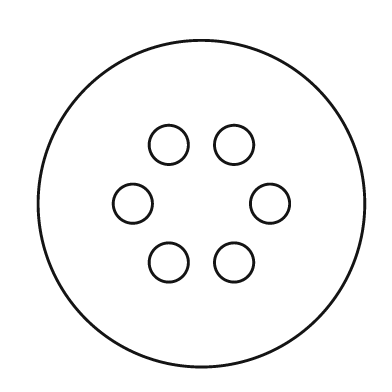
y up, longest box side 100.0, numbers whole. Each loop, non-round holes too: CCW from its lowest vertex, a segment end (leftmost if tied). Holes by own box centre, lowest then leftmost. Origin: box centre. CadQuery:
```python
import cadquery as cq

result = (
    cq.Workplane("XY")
    .moveTo(0.0, 0.0)
    .circle(50.0)
    .moveTo(-10.0, -18.0)
    .circle(6.0)
    .moveTo(10.0, -18.0)
    .circle(6.0)
    .moveTo(-21.0, 0.0)
    .circle(6.0)
    .moveTo(21.0, 0.0)
    .circle(6.0)
    .moveTo(-10.0, 18.0)
    .circle(6.0)
    .moveTo(10.0, 18.0)
    .circle(6.0)
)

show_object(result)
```